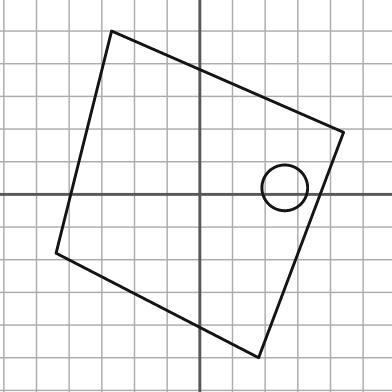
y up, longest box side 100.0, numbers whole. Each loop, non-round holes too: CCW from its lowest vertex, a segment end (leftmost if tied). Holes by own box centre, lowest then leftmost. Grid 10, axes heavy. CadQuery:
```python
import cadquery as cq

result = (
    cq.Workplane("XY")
    .moveTo(18.0, -50.0)
    .lineTo(44.0, 19.0)
    .lineTo(-27.0, 50.0)
    .lineTo(-44.0, -18.0)
    .close()
    .moveTo(26.0, 2.0)
    .circle(7.0)
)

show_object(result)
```